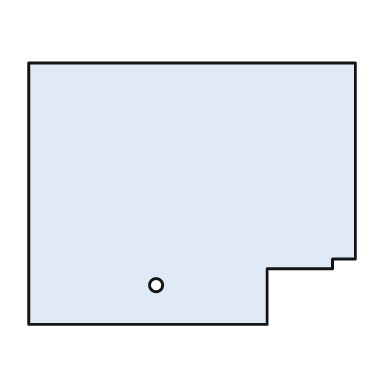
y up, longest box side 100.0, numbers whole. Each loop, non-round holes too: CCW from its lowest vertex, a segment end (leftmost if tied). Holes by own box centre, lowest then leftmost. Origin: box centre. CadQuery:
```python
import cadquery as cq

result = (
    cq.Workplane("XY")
    .moveTo(-50.0, -40.0)
    .lineTo(23.0, -40.0)
    .lineTo(23.0, -23.0)
    .lineTo(43.0, -23.0)
    .lineTo(43.0, -20.0)
    .lineTo(50.0, -20.0)
    .lineTo(50.0, 40.0)
    .lineTo(-50.0, 40.0)
    .close()
    .moveTo(-11.0, -28.0)
    .circle(2.0)
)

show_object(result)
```